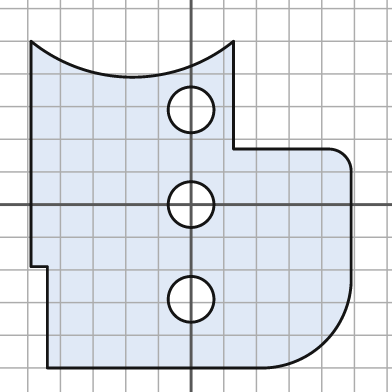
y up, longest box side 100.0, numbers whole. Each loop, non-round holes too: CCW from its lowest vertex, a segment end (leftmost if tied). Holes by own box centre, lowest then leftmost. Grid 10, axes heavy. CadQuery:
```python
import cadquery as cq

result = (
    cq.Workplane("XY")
    .moveTo(-44.0, -50.0)
    .lineTo(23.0, -50.0)
    .threePointArc((41.0, -42.0), (49.0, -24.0))
    .lineTo(49.0, 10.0)
    .threePointArc((47.0, 15.0), (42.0, 17.0))
    .lineTo(13.0, 17.0)
    .lineTo(13.0, 50.0)
    .threePointArc((-18.0, 39.0), (-49.0, 50.0))
    .lineTo(-49.0, -19.0)
    .lineTo(-44.0, -19.0)
    .close()
    .moveTo(0.0, -29.0)
    .circle(7.0)
    .moveTo(0.0, 0.0)
    .circle(7.0)
    .moveTo(0.0, 29.0)
    .circle(7.0)
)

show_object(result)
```